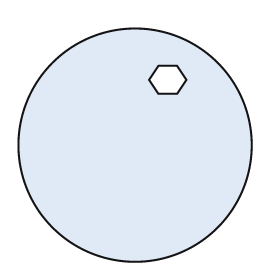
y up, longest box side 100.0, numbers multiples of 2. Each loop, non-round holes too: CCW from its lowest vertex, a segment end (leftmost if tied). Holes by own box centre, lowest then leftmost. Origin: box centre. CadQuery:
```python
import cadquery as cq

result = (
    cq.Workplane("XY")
    .moveTo(0.0, 0.0)
    .circle(50.0)
    .moveTo(10.0, 22.0)
    .lineTo(18.0, 22.0)
    .lineTo(22.0, 28.0)
    .lineTo(18.0, 34.0)
    .lineTo(10.0, 34.0)
    .lineTo(6.0, 28.0)
    .close()
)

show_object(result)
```